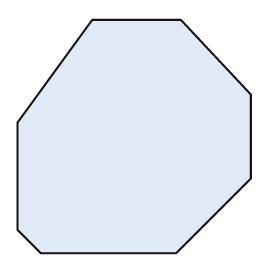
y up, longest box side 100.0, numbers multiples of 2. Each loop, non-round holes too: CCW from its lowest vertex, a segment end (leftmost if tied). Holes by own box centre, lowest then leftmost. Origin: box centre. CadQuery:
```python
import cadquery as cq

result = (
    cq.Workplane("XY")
    .moveTo(-40.0, -50.0)
    .lineTo(18.0, -50.0)
    .lineTo(50.0, -18.0)
    .lineTo(50.0, 18.0)
    .lineTo(20.0, 50.0)
    .lineTo(-18.0, 50.0)
    .lineTo(-50.0, 6.0)
    .lineTo(-50.0, -40.0)
    .close()
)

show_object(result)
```